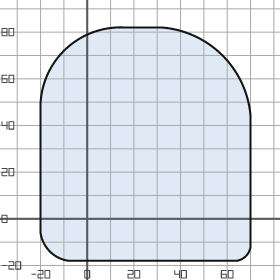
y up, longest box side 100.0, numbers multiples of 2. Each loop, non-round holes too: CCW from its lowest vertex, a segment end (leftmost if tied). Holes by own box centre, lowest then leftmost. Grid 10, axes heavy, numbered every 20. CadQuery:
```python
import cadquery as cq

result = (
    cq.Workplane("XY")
    .moveTo(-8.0, -18.0)
    .lineTo(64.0, -18.0)
    .threePointArc((68.0, -16.0), (70.0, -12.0))
    .lineTo(70.0, 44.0)
    .threePointArc((58.0, 70.0), (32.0, 82.0))
    .lineTo(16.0, 82.0)
    .threePointArc((-10.0, 72.0), (-20.0, 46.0))
    .lineTo(-20.0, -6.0)
    .threePointArc((-16.0, -14.0), (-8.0, -18.0))
    .close()
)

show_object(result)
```